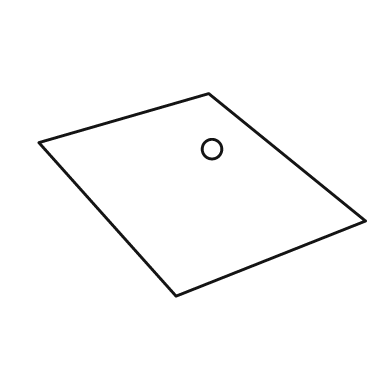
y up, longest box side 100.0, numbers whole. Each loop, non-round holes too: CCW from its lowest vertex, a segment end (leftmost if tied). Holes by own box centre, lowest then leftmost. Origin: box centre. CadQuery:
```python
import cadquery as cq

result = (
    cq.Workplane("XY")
    .moveTo(-8.0, -31.0)
    .lineTo(50.0, -8.0)
    .lineTo(2.0, 31.0)
    .lineTo(-50.0, 16.0)
    .close()
    .moveTo(3.0, 14.0)
    .circle(3.0)
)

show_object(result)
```